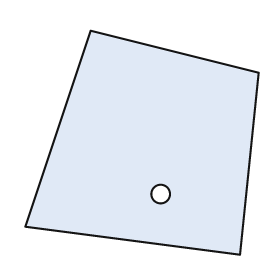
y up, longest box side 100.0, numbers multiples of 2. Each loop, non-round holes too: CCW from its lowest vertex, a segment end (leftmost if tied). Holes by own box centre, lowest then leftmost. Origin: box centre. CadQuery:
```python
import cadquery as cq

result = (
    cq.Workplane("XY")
    .moveTo(42.0, -48.0)
    .lineTo(50.0, 30.0)
    .lineTo(-22.0, 48.0)
    .lineTo(-50.0, -36.0)
    .close()
    .moveTo(8.0, -22.0)
    .circle(4.0)
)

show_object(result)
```